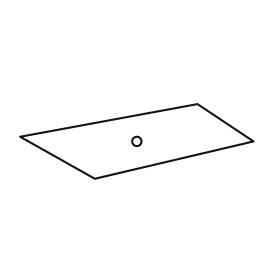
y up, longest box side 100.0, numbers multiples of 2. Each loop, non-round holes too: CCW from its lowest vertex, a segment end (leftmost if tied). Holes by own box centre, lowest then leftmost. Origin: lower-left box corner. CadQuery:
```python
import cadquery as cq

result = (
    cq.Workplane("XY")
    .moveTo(32.0, 0.0)
    .lineTo(100.0, 16.0)
    .lineTo(76.0, 32.0)
    .lineTo(0.0, 18.0)
    .close()
    .moveTo(50.0, 16.0)
    .circle(2.0)
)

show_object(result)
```